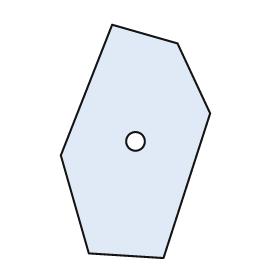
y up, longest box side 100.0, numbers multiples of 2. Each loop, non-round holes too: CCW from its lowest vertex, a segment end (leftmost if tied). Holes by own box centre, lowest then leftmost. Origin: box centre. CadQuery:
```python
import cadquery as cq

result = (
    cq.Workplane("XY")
    .moveTo(12.0, -50.0)
    .lineTo(32.0, 12.0)
    .lineTo(18.0, 42.0)
    .lineTo(-10.0, 50.0)
    .lineTo(-32.0, -6.0)
    .lineTo(-20.0, -48.0)
    .close()
    .moveTo(0.0, 0.0)
    .circle(4.0)
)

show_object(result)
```